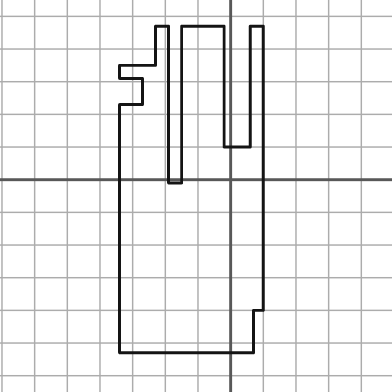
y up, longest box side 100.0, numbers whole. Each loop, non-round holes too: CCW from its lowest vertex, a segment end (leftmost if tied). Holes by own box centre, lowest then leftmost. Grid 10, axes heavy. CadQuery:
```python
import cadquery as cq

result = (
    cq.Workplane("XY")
    .moveTo(-34.0, -53.0)
    .lineTo(7.0, -53.0)
    .lineTo(7.0, -40.0)
    .lineTo(10.0, -40.0)
    .lineTo(10.0, 47.0)
    .lineTo(6.0, 47.0)
    .lineTo(6.0, 10.0)
    .lineTo(-2.0, 10.0)
    .lineTo(-2.0, 47.0)
    .lineTo(-15.0, 47.0)
    .lineTo(-15.0, -1.0)
    .lineTo(-19.0, -1.0)
    .lineTo(-19.0, 47.0)
    .lineTo(-23.0, 47.0)
    .lineTo(-23.0, 35.0)
    .lineTo(-34.0, 35.0)
    .lineTo(-34.0, 31.0)
    .lineTo(-27.0, 31.0)
    .lineTo(-27.0, 23.0)
    .lineTo(-34.0, 23.0)
    .close()
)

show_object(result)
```